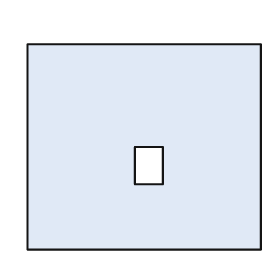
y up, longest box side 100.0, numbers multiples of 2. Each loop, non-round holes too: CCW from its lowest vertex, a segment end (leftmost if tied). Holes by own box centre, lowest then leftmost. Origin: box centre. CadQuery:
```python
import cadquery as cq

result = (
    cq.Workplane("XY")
    .moveTo(-50.0, -44.0)
    .lineTo(50.0, -44.0)
    .lineTo(50.0, 44.0)
    .lineTo(-50.0, 44.0)
    .close()
    .moveTo(-4.0, -16.0)
    .lineTo(8.0, -16.0)
    .lineTo(8.0, 0.0)
    .lineTo(-4.0, 0.0)
    .close()
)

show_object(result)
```